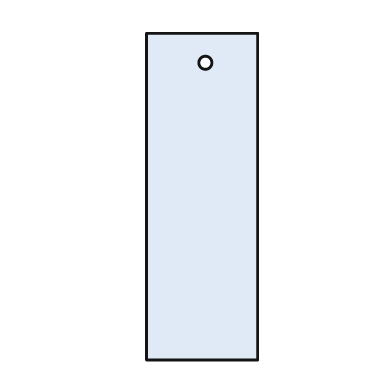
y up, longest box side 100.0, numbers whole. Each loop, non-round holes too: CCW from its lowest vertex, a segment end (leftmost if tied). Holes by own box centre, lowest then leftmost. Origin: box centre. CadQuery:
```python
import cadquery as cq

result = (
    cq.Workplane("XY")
    .moveTo(-17.0, -50.0)
    .lineTo(17.0, -50.0)
    .lineTo(17.0, 50.0)
    .lineTo(-17.0, 50.0)
    .close()
    .moveTo(1.0, 41.0)
    .circle(2.0)
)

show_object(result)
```